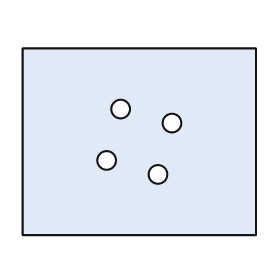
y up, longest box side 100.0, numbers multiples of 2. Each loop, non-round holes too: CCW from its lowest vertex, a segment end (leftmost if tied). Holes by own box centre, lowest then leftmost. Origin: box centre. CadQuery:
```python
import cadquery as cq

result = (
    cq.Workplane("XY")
    .moveTo(-50.0, -40.0)
    .lineTo(50.0, -40.0)
    .lineTo(50.0, 40.0)
    .lineTo(-50.0, 40.0)
    .close()
    .moveTo(8.0, -14.0)
    .circle(4.0)
    .moveTo(-14.0, -8.0)
    .circle(4.0)
    .moveTo(14.0, 8.0)
    .circle(4.0)
    .moveTo(-8.0, 14.0)
    .circle(4.0)
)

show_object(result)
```